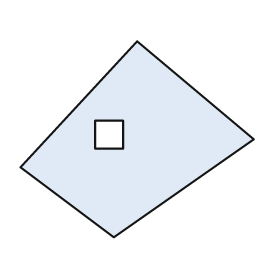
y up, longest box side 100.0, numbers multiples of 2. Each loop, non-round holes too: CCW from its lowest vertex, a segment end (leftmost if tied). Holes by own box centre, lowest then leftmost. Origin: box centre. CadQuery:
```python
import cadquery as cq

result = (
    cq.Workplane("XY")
    .moveTo(-10.0, -42.0)
    .lineTo(50.0, 0.0)
    .lineTo(0.0, 42.0)
    .lineTo(-50.0, -12.0)
    .close()
    .moveTo(-18.0, -4.0)
    .lineTo(-6.0, -4.0)
    .lineTo(-6.0, 8.0)
    .lineTo(-18.0, 8.0)
    .close()
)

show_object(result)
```